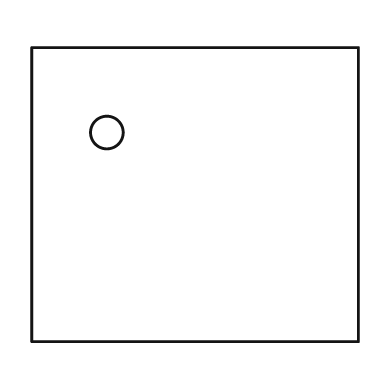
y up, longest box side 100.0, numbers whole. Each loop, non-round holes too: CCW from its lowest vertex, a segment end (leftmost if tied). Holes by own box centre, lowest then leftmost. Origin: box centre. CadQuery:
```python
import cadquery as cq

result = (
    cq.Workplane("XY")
    .moveTo(-50.0, -45.0)
    .lineTo(50.0, -45.0)
    .lineTo(50.0, 45.0)
    .lineTo(-50.0, 45.0)
    .close()
    .moveTo(-27.0, 19.0)
    .circle(5.0)
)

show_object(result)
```